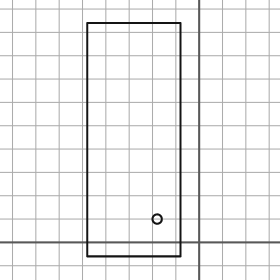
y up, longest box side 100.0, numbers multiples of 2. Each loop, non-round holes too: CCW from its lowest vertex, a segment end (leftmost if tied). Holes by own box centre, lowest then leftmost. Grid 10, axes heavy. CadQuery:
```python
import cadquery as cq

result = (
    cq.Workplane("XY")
    .moveTo(-48.0, -6.0)
    .lineTo(-8.0, -6.0)
    .lineTo(-8.0, 94.0)
    .lineTo(-48.0, 94.0)
    .close()
    .moveTo(-18.0, 10.0)
    .circle(2.0)
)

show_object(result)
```